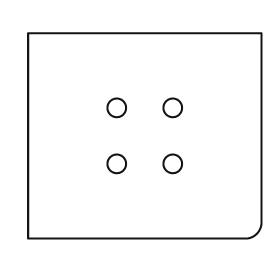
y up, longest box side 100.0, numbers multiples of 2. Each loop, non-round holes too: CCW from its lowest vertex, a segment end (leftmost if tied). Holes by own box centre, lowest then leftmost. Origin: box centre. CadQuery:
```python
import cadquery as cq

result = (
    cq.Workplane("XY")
    .moveTo(-50.0, -44.0)
    .lineTo(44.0, -44.0)
    .threePointArc((48.0, -42.0), (50.0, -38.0))
    .lineTo(50.0, 44.0)
    .lineTo(-50.0, 44.0)
    .close()
    .moveTo(-12.0, -12.0)
    .circle(4.0)
    .moveTo(12.0, -12.0)
    .circle(4.0)
    .moveTo(-12.0, 12.0)
    .circle(4.0)
    .moveTo(12.0, 12.0)
    .circle(4.0)
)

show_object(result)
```